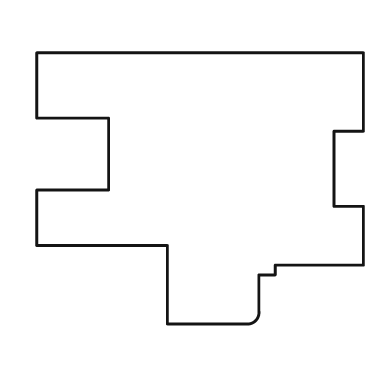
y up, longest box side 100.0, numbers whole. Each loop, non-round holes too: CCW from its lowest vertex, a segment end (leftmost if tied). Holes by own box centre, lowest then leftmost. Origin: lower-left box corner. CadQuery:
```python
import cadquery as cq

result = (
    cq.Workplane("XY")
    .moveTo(40.0, 0.0)
    .lineTo(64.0, 0.0)
    .threePointArc((67.0, 1.0), (68.0, 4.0))
    .lineTo(68.0, 15.0)
    .lineTo(73.0, 15.0)
    .lineTo(73.0, 18.0)
    .lineTo(100.0, 18.0)
    .lineTo(100.0, 36.0)
    .lineTo(91.0, 36.0)
    .lineTo(91.0, 59.0)
    .lineTo(100.0, 59.0)
    .lineTo(100.0, 83.0)
    .lineTo(0.0, 83.0)
    .lineTo(0.0, 63.0)
    .lineTo(22.0, 63.0)
    .lineTo(22.0, 41.0)
    .lineTo(0.0, 41.0)
    .lineTo(0.0, 24.0)
    .lineTo(40.0, 24.0)
    .close()
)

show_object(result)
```